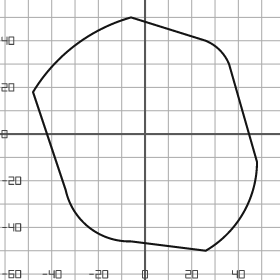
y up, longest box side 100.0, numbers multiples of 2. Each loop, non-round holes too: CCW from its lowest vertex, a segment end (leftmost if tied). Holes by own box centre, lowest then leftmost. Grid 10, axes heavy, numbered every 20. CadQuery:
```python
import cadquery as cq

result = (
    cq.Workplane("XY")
    .moveTo(26.0, -50.0)
    .threePointArc((42.0, -34.0), (48.0, -12.0))
    .lineTo(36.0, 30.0)
    .threePointArc((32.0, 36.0), (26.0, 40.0))
    .lineTo(-6.0, 50.0)
    .threePointArc((-30.0, 38.0), (-48.0, 18.0))
    .lineTo(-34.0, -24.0)
    .threePointArc((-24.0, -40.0), (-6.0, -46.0))
    .close()
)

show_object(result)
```